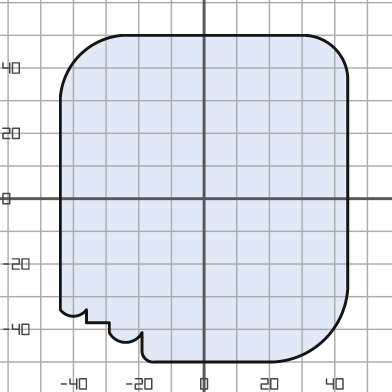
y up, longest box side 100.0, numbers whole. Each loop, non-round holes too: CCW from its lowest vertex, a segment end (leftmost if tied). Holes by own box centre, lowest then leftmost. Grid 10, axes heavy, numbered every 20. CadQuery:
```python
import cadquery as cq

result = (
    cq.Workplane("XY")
    .moveTo(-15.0, -50.0)
    .lineTo(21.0, -50.0)
    .threePointArc((37.0, -43.0), (44.0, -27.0))
    .lineTo(44.0, 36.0)
    .threePointArc((40.0, 46.0), (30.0, 50.0))
    .lineTo(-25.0, 50.0)
    .threePointArc((-38.0, 44.0), (-44.0, 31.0))
    .lineTo(-44.0, -34.0)
    .threePointArc((-40.0, -36.0), (-36.0, -34.0))
    .lineTo(-36.0, -38.0)
    .lineTo(-29.0, -38.0)
    .lineTo(-29.0, -41.0)
    .threePointArc((-24.0, -44.0), (-19.0, -41.0))
    .lineTo(-19.0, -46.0)
    .threePointArc((-18.0, -49.0), (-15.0, -50.0))
    .close()
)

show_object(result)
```